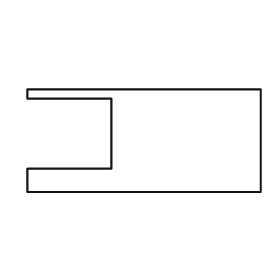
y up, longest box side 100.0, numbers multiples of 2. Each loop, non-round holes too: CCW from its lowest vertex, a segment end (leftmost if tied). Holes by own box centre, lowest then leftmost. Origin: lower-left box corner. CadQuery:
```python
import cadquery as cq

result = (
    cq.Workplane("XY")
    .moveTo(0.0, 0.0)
    .lineTo(100.0, 0.0)
    .lineTo(100.0, 44.0)
    .lineTo(0.0, 44.0)
    .lineTo(0.0, 40.0)
    .lineTo(36.0, 40.0)
    .lineTo(36.0, 10.0)
    .lineTo(0.0, 10.0)
    .close()
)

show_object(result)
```